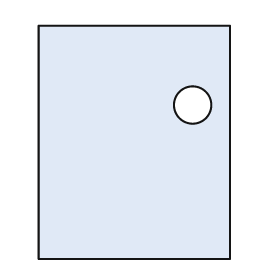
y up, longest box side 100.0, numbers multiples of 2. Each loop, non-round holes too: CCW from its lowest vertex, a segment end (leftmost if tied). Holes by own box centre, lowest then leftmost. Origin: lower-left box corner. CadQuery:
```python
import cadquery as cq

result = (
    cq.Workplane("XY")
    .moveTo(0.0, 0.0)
    .lineTo(82.0, 0.0)
    .lineTo(82.0, 100.0)
    .lineTo(0.0, 100.0)
    .close()
    .moveTo(66.0, 66.0)
    .circle(8.0)
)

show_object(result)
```